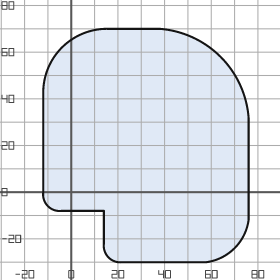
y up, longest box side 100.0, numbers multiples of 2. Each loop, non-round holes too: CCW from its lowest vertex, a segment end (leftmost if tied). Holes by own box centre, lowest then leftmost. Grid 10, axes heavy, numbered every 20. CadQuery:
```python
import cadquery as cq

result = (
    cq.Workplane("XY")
    .moveTo(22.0, -30.0)
    .lineTo(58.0, -30.0)
    .threePointArc((70.0, -24.0), (76.0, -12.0))
    .lineTo(76.0, 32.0)
    .threePointArc((64.0, 58.0), (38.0, 70.0))
    .lineTo(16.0, 70.0)
    .threePointArc((-4.0, 62.0), (-12.0, 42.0))
    .lineTo(-12.0, 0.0)
    .threePointArc((-10.0, -6.0), (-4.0, -8.0))
    .lineTo(14.0, -8.0)
    .lineTo(14.0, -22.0)
    .threePointArc((16.0, -28.0), (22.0, -30.0))
    .close()
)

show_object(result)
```